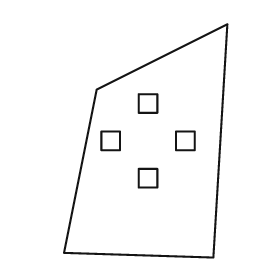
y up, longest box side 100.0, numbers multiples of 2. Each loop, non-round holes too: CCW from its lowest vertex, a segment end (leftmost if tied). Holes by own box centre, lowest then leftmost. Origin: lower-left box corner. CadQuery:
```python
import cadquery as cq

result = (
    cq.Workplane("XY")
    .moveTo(64.0, 0.0)
    .lineTo(70.0, 100.0)
    .lineTo(14.0, 72.0)
    .lineTo(0.0, 2.0)
    .close()
    .moveTo(32.0, 30.0)
    .lineTo(40.0, 30.0)
    .lineTo(40.0, 38.0)
    .lineTo(32.0, 38.0)
    .close()
    .moveTo(16.0, 46.0)
    .lineTo(24.0, 46.0)
    .lineTo(24.0, 54.0)
    .lineTo(16.0, 54.0)
    .close()
    .moveTo(48.0, 46.0)
    .lineTo(56.0, 46.0)
    .lineTo(56.0, 54.0)
    .lineTo(48.0, 54.0)
    .close()
    .moveTo(32.0, 62.0)
    .lineTo(40.0, 62.0)
    .lineTo(40.0, 70.0)
    .lineTo(32.0, 70.0)
    .close()
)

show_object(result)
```